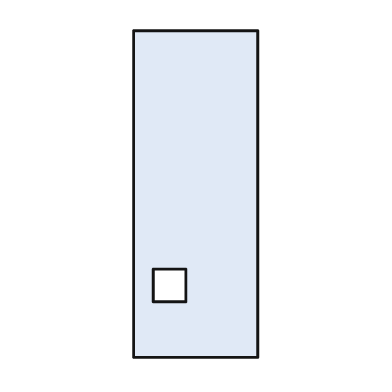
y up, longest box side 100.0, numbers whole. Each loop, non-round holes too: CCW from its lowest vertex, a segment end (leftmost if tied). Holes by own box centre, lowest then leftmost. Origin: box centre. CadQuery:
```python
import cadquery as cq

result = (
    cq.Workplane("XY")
    .moveTo(-19.0, -50.0)
    .lineTo(19.0, -50.0)
    .lineTo(19.0, 50.0)
    .lineTo(-19.0, 50.0)
    .close()
    .moveTo(-13.0, -33.0)
    .lineTo(-3.0, -33.0)
    .lineTo(-3.0, -23.0)
    .lineTo(-13.0, -23.0)
    .close()
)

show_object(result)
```